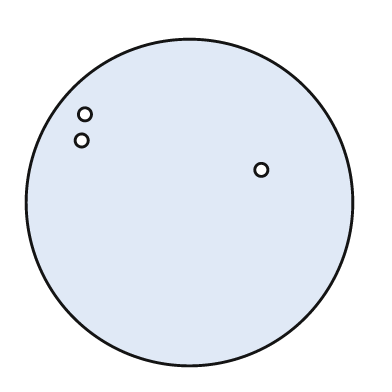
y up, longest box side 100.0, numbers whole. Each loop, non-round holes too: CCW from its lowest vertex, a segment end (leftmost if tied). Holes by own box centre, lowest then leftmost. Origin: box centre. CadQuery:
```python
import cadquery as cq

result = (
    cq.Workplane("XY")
    .moveTo(0.0, 0.0)
    .circle(50.0)
    .moveTo(22.0, 10.0)
    .circle(2.0)
    .moveTo(-33.0, 19.0)
    .circle(2.0)
    .moveTo(-32.0, 27.0)
    .circle(2.0)
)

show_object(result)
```